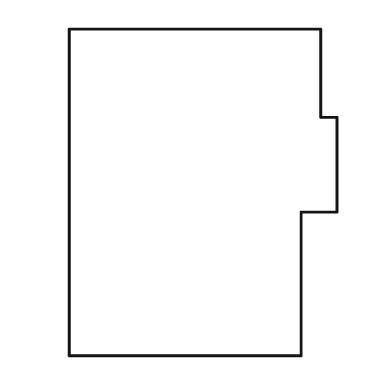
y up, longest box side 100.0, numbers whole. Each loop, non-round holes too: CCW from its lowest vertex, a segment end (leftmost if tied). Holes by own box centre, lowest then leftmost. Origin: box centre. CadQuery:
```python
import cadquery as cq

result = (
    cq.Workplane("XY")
    .moveTo(-41.0, -50.0)
    .lineTo(30.0, -50.0)
    .lineTo(30.0, -6.0)
    .lineTo(41.0, -6.0)
    .lineTo(41.0, 23.0)
    .lineTo(36.0, 23.0)
    .lineTo(36.0, 50.0)
    .lineTo(-41.0, 50.0)
    .close()
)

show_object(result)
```